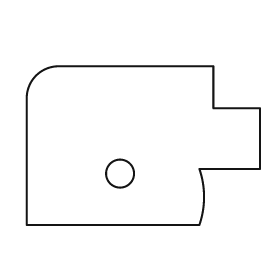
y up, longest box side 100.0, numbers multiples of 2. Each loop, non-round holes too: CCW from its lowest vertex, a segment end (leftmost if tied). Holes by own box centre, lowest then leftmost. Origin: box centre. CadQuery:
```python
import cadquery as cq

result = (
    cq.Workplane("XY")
    .moveTo(-50.0, -34.0)
    .lineTo(24.0, -34.0)
    .threePointArc((26.0, -22.0), (24.0, -10.0))
    .lineTo(50.0, -10.0)
    .lineTo(50.0, 16.0)
    .lineTo(30.0, 16.0)
    .lineTo(30.0, 34.0)
    .lineTo(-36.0, 34.0)
    .threePointArc((-46.0, 30.0), (-50.0, 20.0))
    .close()
    .moveTo(-10.0, -12.0)
    .circle(6.0)
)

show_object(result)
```